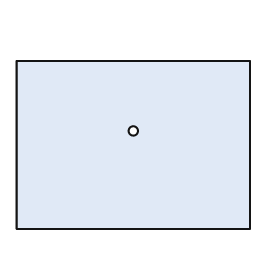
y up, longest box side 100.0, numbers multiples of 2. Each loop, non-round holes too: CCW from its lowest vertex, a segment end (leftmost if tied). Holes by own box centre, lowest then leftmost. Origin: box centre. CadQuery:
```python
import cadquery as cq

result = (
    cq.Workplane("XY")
    .moveTo(-50.0, -36.0)
    .lineTo(50.0, -36.0)
    .lineTo(50.0, 36.0)
    .lineTo(-50.0, 36.0)
    .close()
    .moveTo(0.0, 6.0)
    .circle(2.0)
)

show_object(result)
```